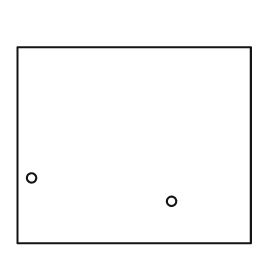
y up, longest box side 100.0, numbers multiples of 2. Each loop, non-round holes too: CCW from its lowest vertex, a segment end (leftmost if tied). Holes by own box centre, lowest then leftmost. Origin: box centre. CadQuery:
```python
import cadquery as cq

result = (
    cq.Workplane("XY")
    .moveTo(-50.0, -42.0)
    .lineTo(50.0, -42.0)
    .lineTo(50.0, 42.0)
    .lineTo(-50.0, 42.0)
    .close()
    .moveTo(16.0, -24.0)
    .circle(2.0)
    .moveTo(-44.0, -14.0)
    .circle(2.0)
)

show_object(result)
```